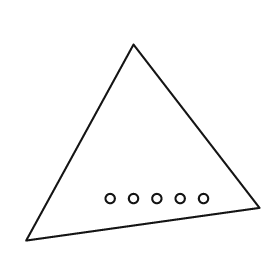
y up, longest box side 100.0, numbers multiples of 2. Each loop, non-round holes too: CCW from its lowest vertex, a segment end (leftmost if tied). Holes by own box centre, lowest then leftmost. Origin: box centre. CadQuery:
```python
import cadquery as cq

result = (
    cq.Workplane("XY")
    .moveTo(-50.0, -42.0)
    .lineTo(50.0, -28.0)
    .lineTo(-4.0, 42.0)
    .close()
    .moveTo(-14.0, -24.0)
    .circle(2.0)
    .moveTo(-4.0, -24.0)
    .circle(2.0)
    .moveTo(6.0, -24.0)
    .circle(2.0)
    .moveTo(16.0, -24.0)
    .circle(2.0)
    .moveTo(26.0, -24.0)
    .circle(2.0)
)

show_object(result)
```